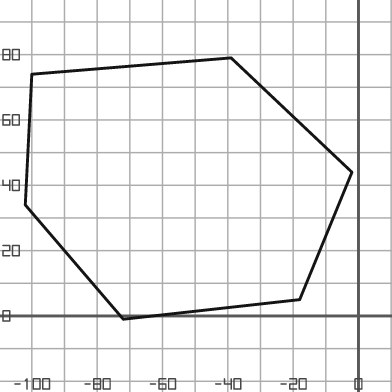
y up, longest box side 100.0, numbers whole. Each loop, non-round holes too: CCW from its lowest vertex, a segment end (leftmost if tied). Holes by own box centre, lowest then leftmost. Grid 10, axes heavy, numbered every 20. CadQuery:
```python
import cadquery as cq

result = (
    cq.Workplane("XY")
    .moveTo(-72.0, -1.0)
    .lineTo(-18.0, 5.0)
    .lineTo(-2.0, 44.0)
    .lineTo(-39.0, 79.0)
    .lineTo(-100.0, 74.0)
    .lineTo(-102.0, 34.0)
    .close()
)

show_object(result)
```